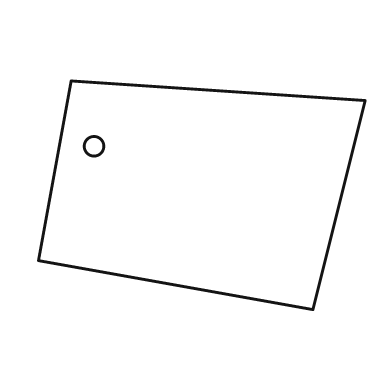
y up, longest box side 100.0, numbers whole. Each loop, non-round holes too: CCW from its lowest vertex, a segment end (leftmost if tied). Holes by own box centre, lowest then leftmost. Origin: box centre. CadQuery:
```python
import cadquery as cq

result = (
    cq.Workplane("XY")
    .moveTo(34.0, -35.0)
    .lineTo(50.0, 29.0)
    .lineTo(-40.0, 35.0)
    .lineTo(-50.0, -20.0)
    .close()
    .moveTo(-33.0, 15.0)
    .circle(3.0)
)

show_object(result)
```